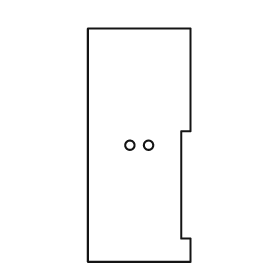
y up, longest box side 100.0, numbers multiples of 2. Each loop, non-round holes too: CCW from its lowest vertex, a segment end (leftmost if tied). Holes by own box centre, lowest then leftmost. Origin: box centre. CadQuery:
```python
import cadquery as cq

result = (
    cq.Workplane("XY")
    .moveTo(-22.0, -50.0)
    .lineTo(22.0, -50.0)
    .lineTo(22.0, -40.0)
    .lineTo(18.0, -40.0)
    .lineTo(18.0, 6.0)
    .lineTo(22.0, 6.0)
    .lineTo(22.0, 50.0)
    .lineTo(-22.0, 50.0)
    .close()
    .moveTo(-4.0, 0.0)
    .circle(2.0)
    .moveTo(4.0, 0.0)
    .circle(2.0)
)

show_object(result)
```